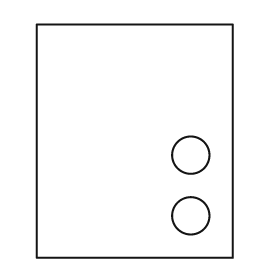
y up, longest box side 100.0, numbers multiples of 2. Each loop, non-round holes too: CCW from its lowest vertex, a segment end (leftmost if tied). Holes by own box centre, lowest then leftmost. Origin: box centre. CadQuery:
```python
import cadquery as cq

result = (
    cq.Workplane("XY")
    .moveTo(-42.0, -50.0)
    .lineTo(42.0, -50.0)
    .lineTo(42.0, 50.0)
    .lineTo(-42.0, 50.0)
    .close()
    .moveTo(24.0, -32.0)
    .circle(8.0)
    .moveTo(24.0, -6.0)
    .circle(8.0)
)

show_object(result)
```